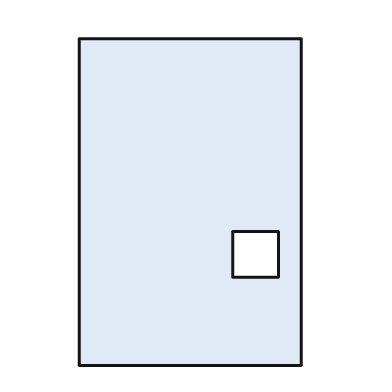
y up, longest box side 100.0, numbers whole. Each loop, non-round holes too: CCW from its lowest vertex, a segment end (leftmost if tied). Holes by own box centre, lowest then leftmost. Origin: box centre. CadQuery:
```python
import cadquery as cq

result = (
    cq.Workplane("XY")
    .moveTo(-34.0, -50.0)
    .lineTo(34.0, -50.0)
    .lineTo(34.0, 50.0)
    .lineTo(-34.0, 50.0)
    .close()
    .moveTo(13.0, -23.0)
    .lineTo(27.0, -23.0)
    .lineTo(27.0, -9.0)
    .lineTo(13.0, -9.0)
    .close()
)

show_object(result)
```